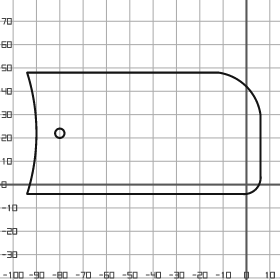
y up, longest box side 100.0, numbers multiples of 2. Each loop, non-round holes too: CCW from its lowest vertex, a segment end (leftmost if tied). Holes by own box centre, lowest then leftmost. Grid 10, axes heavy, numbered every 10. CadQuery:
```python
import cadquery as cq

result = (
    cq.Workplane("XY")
    .moveTo(-94.0, -4.0)
    .lineTo(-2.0, -4.0)
    .threePointArc((4.0, -2.0), (6.0, 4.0))
    .lineTo(6.0, 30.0)
    .threePointArc((0.0, 42.0), (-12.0, 48.0))
    .lineTo(-94.0, 48.0)
    .threePointArc((-90.0, 22.0), (-94.0, -4.0))
    .close()
    .moveTo(-80.0, 22.0)
    .circle(2.0)
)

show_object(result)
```